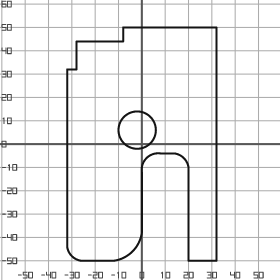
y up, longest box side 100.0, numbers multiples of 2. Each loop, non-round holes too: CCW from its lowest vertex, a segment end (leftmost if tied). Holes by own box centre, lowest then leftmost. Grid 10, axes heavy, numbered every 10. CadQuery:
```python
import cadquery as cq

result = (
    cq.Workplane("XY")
    .moveTo(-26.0, -50.0)
    .lineTo(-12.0, -50.0)
    .threePointArc((-4.0, -46.0), (0.0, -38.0))
    .lineTo(0.0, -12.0)
    .threePointArc((2.0, -6.0), (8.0, -4.0))
    .lineTo(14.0, -4.0)
    .threePointArc((18.0, -6.0), (20.0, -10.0))
    .lineTo(20.0, -50.0)
    .lineTo(32.0, -50.0)
    .lineTo(32.0, 50.0)
    .lineTo(-8.0, 50.0)
    .lineTo(-8.0, 44.0)
    .lineTo(-28.0, 44.0)
    .lineTo(-28.0, 32.0)
    .lineTo(-32.0, 32.0)
    .lineTo(-32.0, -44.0)
    .threePointArc((-30.0, -48.0), (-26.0, -50.0))
    .close()
    .moveTo(-2.0, 6.0)
    .circle(8.0)
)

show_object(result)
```